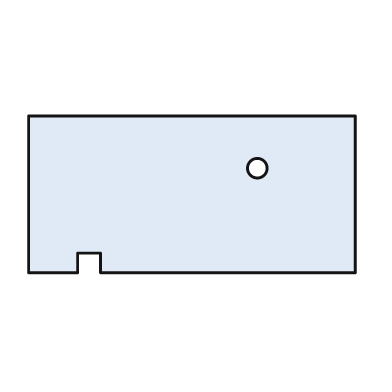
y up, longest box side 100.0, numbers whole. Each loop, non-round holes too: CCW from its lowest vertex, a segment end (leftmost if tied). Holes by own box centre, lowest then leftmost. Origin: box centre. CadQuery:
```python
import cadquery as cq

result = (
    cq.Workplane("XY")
    .moveTo(-50.0, -24.0)
    .lineTo(-35.0, -24.0)
    .lineTo(-35.0, -18.0)
    .lineTo(-28.0, -18.0)
    .lineTo(-28.0, -24.0)
    .lineTo(50.0, -24.0)
    .lineTo(50.0, 24.0)
    .lineTo(-50.0, 24.0)
    .close()
    .moveTo(20.0, 8.0)
    .circle(3.0)
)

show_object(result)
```